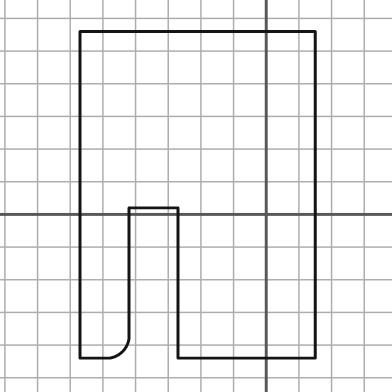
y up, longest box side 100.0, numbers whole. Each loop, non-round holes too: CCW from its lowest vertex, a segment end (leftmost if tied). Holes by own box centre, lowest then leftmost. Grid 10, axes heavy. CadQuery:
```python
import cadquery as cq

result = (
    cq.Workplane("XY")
    .moveTo(-57.0, -44.0)
    .lineTo(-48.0, -44.0)
    .threePointArc((-44.0, -42.0), (-42.0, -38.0))
    .lineTo(-42.0, 2.0)
    .lineTo(-27.0, 2.0)
    .lineTo(-27.0, -44.0)
    .lineTo(15.0, -44.0)
    .lineTo(15.0, 56.0)
    .lineTo(-57.0, 56.0)
    .close()
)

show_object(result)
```